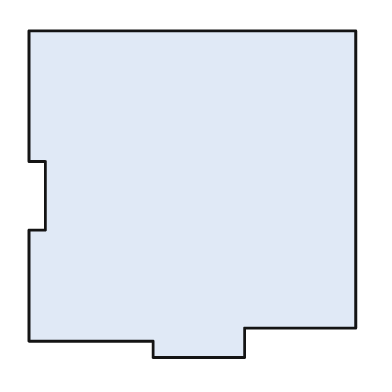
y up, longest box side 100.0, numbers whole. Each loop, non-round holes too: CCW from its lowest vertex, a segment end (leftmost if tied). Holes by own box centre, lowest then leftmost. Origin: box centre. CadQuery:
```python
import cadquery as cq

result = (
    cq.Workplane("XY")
    .moveTo(-12.0, -50.0)
    .lineTo(16.0, -50.0)
    .lineTo(16.0, -41.0)
    .lineTo(50.0, -41.0)
    .lineTo(50.0, 50.0)
    .lineTo(-50.0, 50.0)
    .lineTo(-50.0, 10.0)
    .lineTo(-45.0, 10.0)
    .lineTo(-45.0, -11.0)
    .lineTo(-50.0, -11.0)
    .lineTo(-50.0, -45.0)
    .lineTo(-12.0, -45.0)
    .close()
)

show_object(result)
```